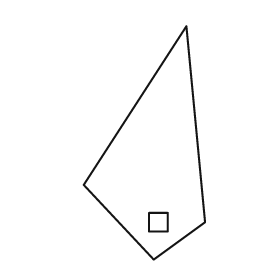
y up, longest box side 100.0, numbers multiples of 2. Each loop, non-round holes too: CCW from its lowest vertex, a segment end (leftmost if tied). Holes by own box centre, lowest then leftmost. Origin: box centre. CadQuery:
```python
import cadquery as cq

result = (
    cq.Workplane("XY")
    .moveTo(4.0, -50.0)
    .lineTo(26.0, -34.0)
    .lineTo(18.0, 50.0)
    .lineTo(-26.0, -18.0)
    .close()
    .moveTo(2.0, -38.0)
    .lineTo(10.0, -38.0)
    .lineTo(10.0, -30.0)
    .lineTo(2.0, -30.0)
    .close()
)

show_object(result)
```